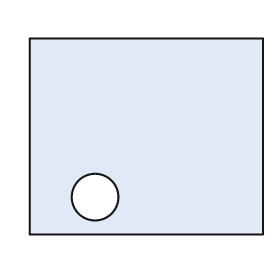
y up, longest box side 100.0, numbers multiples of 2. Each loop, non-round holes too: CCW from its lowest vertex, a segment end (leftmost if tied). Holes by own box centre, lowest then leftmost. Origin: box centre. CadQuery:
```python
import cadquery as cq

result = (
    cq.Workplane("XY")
    .moveTo(-50.0, -42.0)
    .lineTo(50.0, -42.0)
    .lineTo(50.0, 42.0)
    .lineTo(-50.0, 42.0)
    .close()
    .moveTo(-22.0, -26.0)
    .circle(10.0)
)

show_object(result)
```